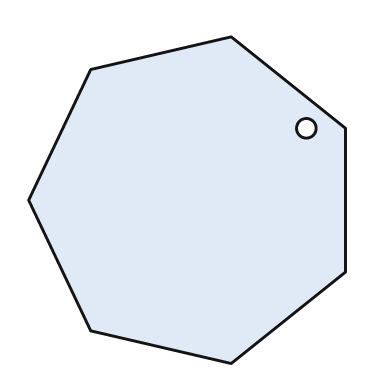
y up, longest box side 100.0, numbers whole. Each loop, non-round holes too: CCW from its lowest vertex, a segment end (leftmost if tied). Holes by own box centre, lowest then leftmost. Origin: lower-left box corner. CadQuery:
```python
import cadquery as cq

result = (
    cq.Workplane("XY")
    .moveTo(62.0, 0.0)
    .lineTo(97.0, 28.0)
    .lineTo(97.0, 72.0)
    .lineTo(62.0, 100.0)
    .lineTo(19.0, 90.0)
    .lineTo(0.0, 50.0)
    .lineTo(19.0, 10.0)
    .close()
    .moveTo(85.0, 72.0)
    .circle(3.0)
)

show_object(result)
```